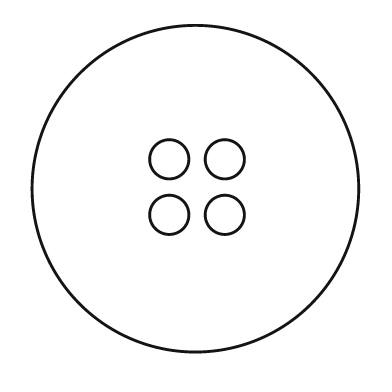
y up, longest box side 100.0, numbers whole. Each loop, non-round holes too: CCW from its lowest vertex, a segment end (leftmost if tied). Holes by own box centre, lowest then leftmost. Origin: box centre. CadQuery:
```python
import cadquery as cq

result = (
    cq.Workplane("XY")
    .moveTo(0.0, 0.0)
    .circle(50.0)
    .moveTo(-8.0, -8.0)
    .circle(6.0)
    .moveTo(9.0, -8.0)
    .circle(6.0)
    .moveTo(-8.0, 9.0)
    .circle(6.0)
    .moveTo(9.0, 9.0)
    .circle(6.0)
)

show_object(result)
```